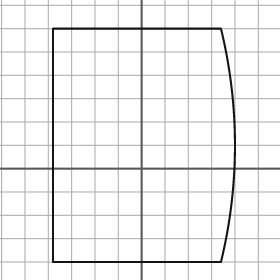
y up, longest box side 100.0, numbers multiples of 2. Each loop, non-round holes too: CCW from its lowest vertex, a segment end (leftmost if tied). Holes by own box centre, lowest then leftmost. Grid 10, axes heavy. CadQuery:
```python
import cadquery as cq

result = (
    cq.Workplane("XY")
    .moveTo(-38.0, -40.0)
    .lineTo(34.0, -40.0)
    .threePointArc((40.0, 10.0), (34.0, 60.0))
    .lineTo(-38.0, 60.0)
    .close()
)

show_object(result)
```